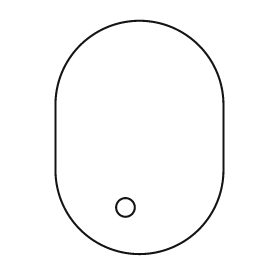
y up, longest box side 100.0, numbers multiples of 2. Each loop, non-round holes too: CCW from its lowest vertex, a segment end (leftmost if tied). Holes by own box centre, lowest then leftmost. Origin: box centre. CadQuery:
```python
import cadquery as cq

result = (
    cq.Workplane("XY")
    .moveTo(-36.0, -14.0)
    .threePointArc((0.0, -50.0), (36.0, -14.0))
    .lineTo(36.0, 14.0)
    .threePointArc((0.0, 50.0), (-36.0, 14.0))
    .close()
    .moveTo(-6.0, -30.0)
    .circle(4.0)
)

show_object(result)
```